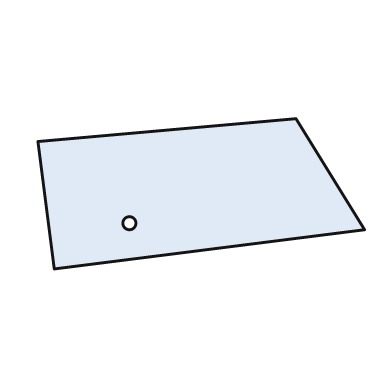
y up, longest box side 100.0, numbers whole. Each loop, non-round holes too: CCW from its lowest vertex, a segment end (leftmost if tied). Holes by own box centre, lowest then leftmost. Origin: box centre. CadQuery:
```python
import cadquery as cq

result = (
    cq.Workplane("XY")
    .moveTo(-45.0, -23.0)
    .lineTo(50.0, -11.0)
    .lineTo(29.0, 23.0)
    .lineTo(-50.0, 16.0)
    .close()
    .moveTo(-22.0, -9.0)
    .circle(2.0)
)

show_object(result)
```